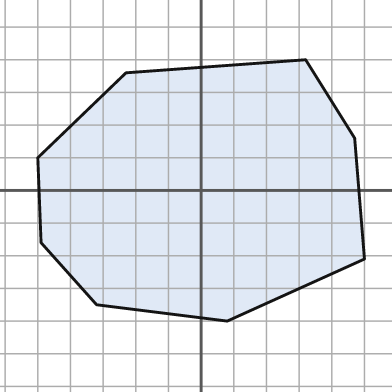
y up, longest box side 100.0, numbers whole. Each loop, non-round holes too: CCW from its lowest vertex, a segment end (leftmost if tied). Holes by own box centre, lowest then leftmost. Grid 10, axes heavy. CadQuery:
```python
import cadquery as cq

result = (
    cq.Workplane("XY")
    .moveTo(8.0, -40.0)
    .lineTo(50.0, -21.0)
    .lineTo(47.0, 16.0)
    .lineTo(32.0, 40.0)
    .lineTo(-23.0, 36.0)
    .lineTo(-50.0, 10.0)
    .lineTo(-49.0, -16.0)
    .lineTo(-32.0, -35.0)
    .close()
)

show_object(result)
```